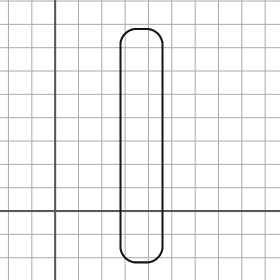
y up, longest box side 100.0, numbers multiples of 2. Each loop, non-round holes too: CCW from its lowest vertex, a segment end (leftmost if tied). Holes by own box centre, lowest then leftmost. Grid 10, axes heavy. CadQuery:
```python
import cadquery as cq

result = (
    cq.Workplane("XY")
    .moveTo(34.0, -22.0)
    .lineTo(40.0, -22.0)
    .threePointArc((44.0, -20.0), (46.0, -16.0))
    .lineTo(46.0, 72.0)
    .threePointArc((44.0, 76.0), (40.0, 78.0))
    .lineTo(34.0, 78.0)
    .threePointArc((30.0, 76.0), (28.0, 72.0))
    .lineTo(28.0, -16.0)
    .threePointArc((30.0, -20.0), (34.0, -22.0))
    .close()
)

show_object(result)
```